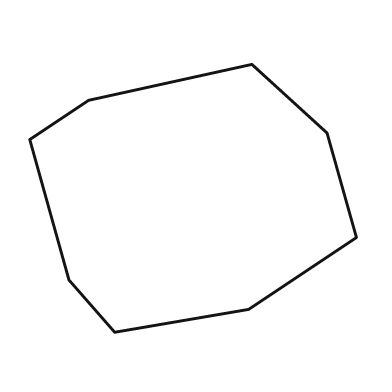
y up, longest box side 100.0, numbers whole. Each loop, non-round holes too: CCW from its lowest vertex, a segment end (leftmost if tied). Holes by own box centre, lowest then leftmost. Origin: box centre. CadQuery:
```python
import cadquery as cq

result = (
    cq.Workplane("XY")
    .moveTo(-24.0, -41.0)
    .lineTo(17.0, -34.0)
    .lineTo(50.0, -12.0)
    .lineTo(41.0, 20.0)
    .lineTo(18.0, 41.0)
    .lineTo(-32.0, 30.0)
    .lineTo(-50.0, 18.0)
    .lineTo(-38.0, -25.0)
    .close()
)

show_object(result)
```